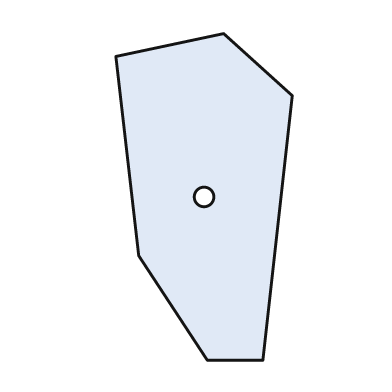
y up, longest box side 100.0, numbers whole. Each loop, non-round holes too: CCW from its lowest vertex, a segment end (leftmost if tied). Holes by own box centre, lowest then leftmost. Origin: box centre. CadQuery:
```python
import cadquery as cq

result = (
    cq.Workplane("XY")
    .moveTo(1.0, -50.0)
    .lineTo(18.0, -50.0)
    .lineTo(27.0, 31.0)
    .lineTo(6.0, 50.0)
    .lineTo(-27.0, 43.0)
    .lineTo(-20.0, -18.0)
    .close()
    .moveTo(0.0, 0.0)
    .circle(3.0)
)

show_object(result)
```